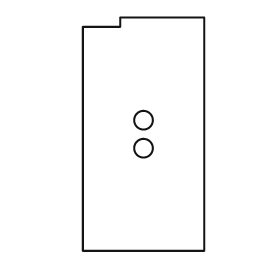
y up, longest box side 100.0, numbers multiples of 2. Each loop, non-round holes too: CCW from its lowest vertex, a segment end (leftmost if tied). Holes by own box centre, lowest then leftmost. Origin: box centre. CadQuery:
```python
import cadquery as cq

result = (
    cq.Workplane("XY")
    .moveTo(-26.0, -50.0)
    .lineTo(26.0, -50.0)
    .lineTo(26.0, 50.0)
    .lineTo(-10.0, 50.0)
    .lineTo(-10.0, 46.0)
    .lineTo(-26.0, 46.0)
    .close()
    .moveTo(0.0, -6.0)
    .circle(4.0)
    .moveTo(0.0, 6.0)
    .circle(4.0)
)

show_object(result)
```